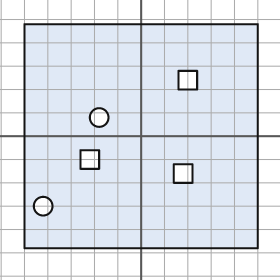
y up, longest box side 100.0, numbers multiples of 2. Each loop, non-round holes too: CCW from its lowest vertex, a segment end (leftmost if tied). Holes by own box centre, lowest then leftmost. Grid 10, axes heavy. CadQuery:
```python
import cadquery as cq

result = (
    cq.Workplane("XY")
    .moveTo(-50.0, -48.0)
    .lineTo(50.0, -48.0)
    .lineTo(50.0, 48.0)
    .lineTo(-50.0, 48.0)
    .close()
    .moveTo(-42.0, -30.0)
    .circle(4.0)
    .moveTo(14.0, -20.0)
    .lineTo(22.0, -20.0)
    .lineTo(22.0, -12.0)
    .lineTo(14.0, -12.0)
    .close()
    .moveTo(-26.0, -14.0)
    .lineTo(-18.0, -14.0)
    .lineTo(-18.0, -6.0)
    .lineTo(-26.0, -6.0)
    .close()
    .moveTo(-18.0, 8.0)
    .circle(4.0)
    .moveTo(16.0, 20.0)
    .lineTo(24.0, 20.0)
    .lineTo(24.0, 28.0)
    .lineTo(16.0, 28.0)
    .close()
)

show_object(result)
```